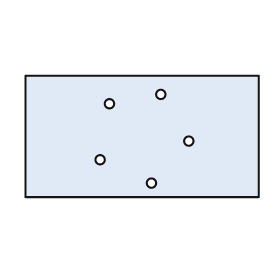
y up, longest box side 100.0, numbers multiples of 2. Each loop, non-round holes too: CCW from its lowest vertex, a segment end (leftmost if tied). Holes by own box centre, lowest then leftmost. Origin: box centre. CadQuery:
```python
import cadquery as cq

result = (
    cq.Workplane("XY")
    .moveTo(-50.0, -26.0)
    .lineTo(50.0, -26.0)
    .lineTo(50.0, 26.0)
    .lineTo(-50.0, 26.0)
    .close()
    .moveTo(4.0, -20.0)
    .circle(2.0)
    .moveTo(-18.0, -10.0)
    .circle(2.0)
    .moveTo(20.0, -2.0)
    .circle(2.0)
    .moveTo(-14.0, 14.0)
    .circle(2.0)
    .moveTo(8.0, 18.0)
    .circle(2.0)
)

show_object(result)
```